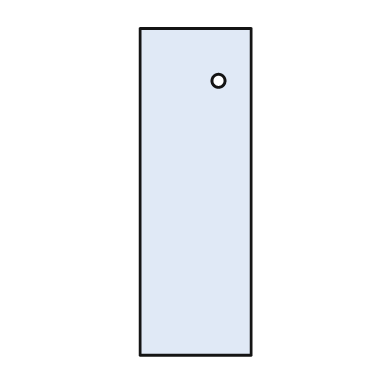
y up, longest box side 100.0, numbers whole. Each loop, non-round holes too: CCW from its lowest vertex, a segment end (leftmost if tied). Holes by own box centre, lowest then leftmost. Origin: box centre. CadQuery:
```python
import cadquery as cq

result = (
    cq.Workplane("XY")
    .moveTo(-17.0, -50.0)
    .lineTo(17.0, -50.0)
    .lineTo(17.0, 50.0)
    .lineTo(-17.0, 50.0)
    .close()
    .moveTo(7.0, 34.0)
    .circle(2.0)
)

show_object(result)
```